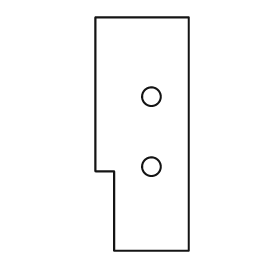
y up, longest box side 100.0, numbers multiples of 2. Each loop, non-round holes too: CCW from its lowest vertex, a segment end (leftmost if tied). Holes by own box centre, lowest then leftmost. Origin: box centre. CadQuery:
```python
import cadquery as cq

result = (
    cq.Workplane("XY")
    .moveTo(-12.0, -50.0)
    .lineTo(20.0, -50.0)
    .lineTo(20.0, 50.0)
    .lineTo(-20.0, 50.0)
    .lineTo(-20.0, -16.0)
    .lineTo(-12.0, -16.0)
    .close()
    .moveTo(4.0, -14.0)
    .circle(4.0)
    .moveTo(4.0, 16.0)
    .circle(4.0)
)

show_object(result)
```